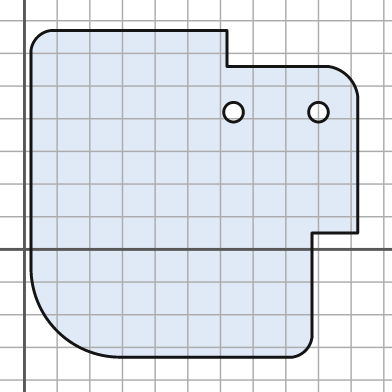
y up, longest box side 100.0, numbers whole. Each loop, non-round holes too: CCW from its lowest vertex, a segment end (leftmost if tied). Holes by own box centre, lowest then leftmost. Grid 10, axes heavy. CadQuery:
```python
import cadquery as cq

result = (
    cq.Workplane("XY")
    .moveTo(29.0, -33.0)
    .lineTo(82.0, -33.0)
    .threePointArc((86.0, -31.0), (88.0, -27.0))
    .lineTo(88.0, 5.0)
    .lineTo(102.0, 5.0)
    .lineTo(102.0, 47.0)
    .threePointArc((99.0, 53.0), (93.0, 56.0))
    .lineTo(62.0, 56.0)
    .lineTo(62.0, 67.0)
    .lineTo(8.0, 67.0)
    .threePointArc((4.0, 65.0), (2.0, 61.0))
    .lineTo(2.0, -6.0)
    .threePointArc((10.0, -25.0), (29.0, -33.0))
    .close()
    .moveTo(64.0, 42.0)
    .circle(3.0)
    .moveTo(90.0, 42.0)
    .circle(3.0)
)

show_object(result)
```